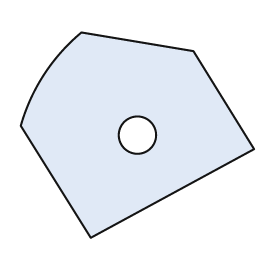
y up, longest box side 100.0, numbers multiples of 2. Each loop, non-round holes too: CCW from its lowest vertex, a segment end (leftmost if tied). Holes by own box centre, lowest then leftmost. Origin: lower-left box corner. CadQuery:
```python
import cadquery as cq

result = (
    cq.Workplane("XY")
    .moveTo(30.0, 0.0)
    .lineTo(100.0, 38.0)
    .lineTo(74.0, 80.0)
    .lineTo(26.0, 88.0)
    .threePointArc((10.0, 70.0), (0.0, 48.0))
    .close()
    .moveTo(50.0, 44.0)
    .circle(8.0)
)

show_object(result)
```